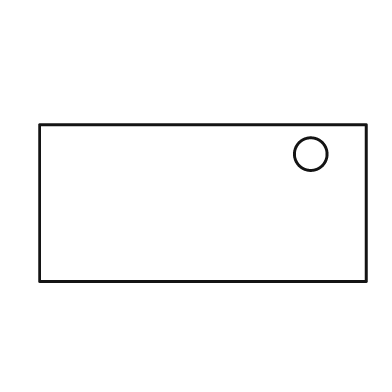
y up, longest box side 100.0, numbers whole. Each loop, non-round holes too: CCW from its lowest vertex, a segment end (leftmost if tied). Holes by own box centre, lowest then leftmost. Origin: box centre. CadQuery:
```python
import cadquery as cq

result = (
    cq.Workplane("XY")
    .moveTo(-50.0, -24.0)
    .lineTo(50.0, -24.0)
    .lineTo(50.0, 24.0)
    .lineTo(-50.0, 24.0)
    .close()
    .moveTo(33.0, 15.0)
    .circle(5.0)
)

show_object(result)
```